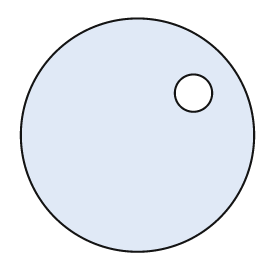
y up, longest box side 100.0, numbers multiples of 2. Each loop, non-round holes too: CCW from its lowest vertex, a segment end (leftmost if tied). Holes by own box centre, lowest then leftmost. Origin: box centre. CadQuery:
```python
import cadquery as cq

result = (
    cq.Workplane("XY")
    .moveTo(0.0, 0.0)
    .circle(50.0)
    .moveTo(24.0, 18.0)
    .circle(8.0)
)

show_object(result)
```